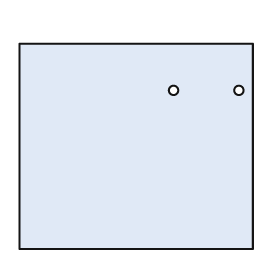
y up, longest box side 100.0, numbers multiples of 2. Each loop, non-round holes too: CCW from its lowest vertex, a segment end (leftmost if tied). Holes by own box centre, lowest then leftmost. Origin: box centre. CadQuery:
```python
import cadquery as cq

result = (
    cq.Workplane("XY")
    .moveTo(-50.0, -44.0)
    .lineTo(50.0, -44.0)
    .lineTo(50.0, 44.0)
    .lineTo(-50.0, 44.0)
    .close()
    .moveTo(16.0, 24.0)
    .circle(2.0)
    .moveTo(44.0, 24.0)
    .circle(2.0)
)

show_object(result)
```